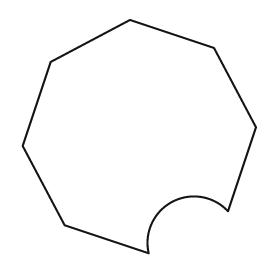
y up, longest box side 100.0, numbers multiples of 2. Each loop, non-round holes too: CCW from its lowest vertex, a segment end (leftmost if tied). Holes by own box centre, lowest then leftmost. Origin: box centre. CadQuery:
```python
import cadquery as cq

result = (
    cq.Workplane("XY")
    .moveTo(4.0, -50.0)
    .threePointArc((14.0, -28.0), (38.0, -32.0))
    .lineTo(50.0, 4.0)
    .lineTo(32.0, 38.0)
    .lineTo(-4.0, 50.0)
    .lineTo(-38.0, 32.0)
    .lineTo(-50.0, -4.0)
    .lineTo(-32.0, -38.0)
    .close()
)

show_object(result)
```